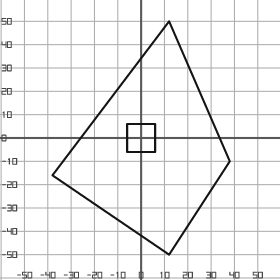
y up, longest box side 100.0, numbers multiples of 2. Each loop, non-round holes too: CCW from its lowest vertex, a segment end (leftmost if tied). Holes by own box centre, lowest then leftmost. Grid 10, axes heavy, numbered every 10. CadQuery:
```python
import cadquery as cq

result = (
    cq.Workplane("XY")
    .moveTo(12.0, -50.0)
    .lineTo(38.0, -10.0)
    .lineTo(12.0, 50.0)
    .lineTo(-38.0, -16.0)
    .close()
    .moveTo(-6.0, -6.0)
    .lineTo(6.0, -6.0)
    .lineTo(6.0, 6.0)
    .lineTo(-6.0, 6.0)
    .close()
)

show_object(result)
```